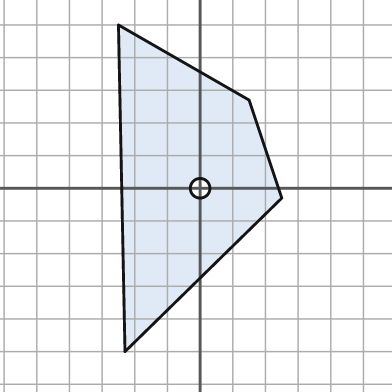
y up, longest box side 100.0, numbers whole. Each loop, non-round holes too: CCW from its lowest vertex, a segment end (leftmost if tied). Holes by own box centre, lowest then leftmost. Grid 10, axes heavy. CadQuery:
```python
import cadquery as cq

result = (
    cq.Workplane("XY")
    .moveTo(-23.0, -50.0)
    .lineTo(25.0, -3.0)
    .lineTo(15.0, 27.0)
    .lineTo(-25.0, 50.0)
    .close()
    .moveTo(0.0, 0.0)
    .circle(3.0)
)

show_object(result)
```